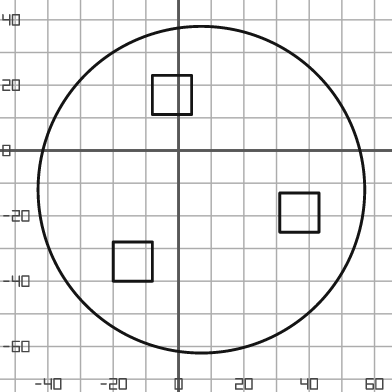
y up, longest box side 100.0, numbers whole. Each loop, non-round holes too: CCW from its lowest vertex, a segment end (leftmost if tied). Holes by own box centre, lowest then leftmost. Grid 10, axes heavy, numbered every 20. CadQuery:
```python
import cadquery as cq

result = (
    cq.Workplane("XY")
    .moveTo(7.0, -12.0)
    .circle(50.0)
    .moveTo(-20.0, -40.0)
    .lineTo(-8.0, -40.0)
    .lineTo(-8.0, -28.0)
    .lineTo(-20.0, -28.0)
    .close()
    .moveTo(31.0, -25.0)
    .lineTo(43.0, -25.0)
    .lineTo(43.0, -13.0)
    .lineTo(31.0, -13.0)
    .close()
    .moveTo(-8.0, 11.0)
    .lineTo(4.0, 11.0)
    .lineTo(4.0, 23.0)
    .lineTo(-8.0, 23.0)
    .close()
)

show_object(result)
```